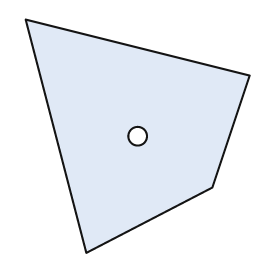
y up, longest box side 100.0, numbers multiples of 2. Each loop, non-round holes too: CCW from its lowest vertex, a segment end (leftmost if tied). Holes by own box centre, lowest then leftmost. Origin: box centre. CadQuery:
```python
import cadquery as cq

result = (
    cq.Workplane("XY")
    .moveTo(-22.0, -50.0)
    .lineTo(32.0, -22.0)
    .lineTo(48.0, 26.0)
    .lineTo(-48.0, 50.0)
    .close()
    .moveTo(0.0, 0.0)
    .circle(4.0)
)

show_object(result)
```